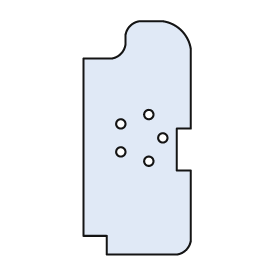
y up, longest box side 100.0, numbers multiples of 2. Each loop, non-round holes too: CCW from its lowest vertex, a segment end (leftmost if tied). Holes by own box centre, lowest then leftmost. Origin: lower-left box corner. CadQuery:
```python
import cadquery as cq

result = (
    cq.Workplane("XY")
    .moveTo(10.0, 0.0)
    .lineTo(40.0, 0.0)
    .threePointArc((44.0, 2.0), (46.0, 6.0))
    .lineTo(46.0, 36.0)
    .lineTo(40.0, 36.0)
    .lineTo(40.0, 54.0)
    .lineTo(46.0, 54.0)
    .lineTo(46.0, 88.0)
    .threePointArc((42.0, 96.0), (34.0, 100.0))
    .lineTo(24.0, 100.0)
    .threePointArc((20.0, 98.0), (18.0, 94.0))
    .lineTo(18.0, 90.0)
    .threePointArc((16.0, 86.0), (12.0, 84.0))
    .lineTo(0.0, 84.0)
    .lineTo(0.0, 8.0)
    .lineTo(10.0, 8.0)
    .close()
    .moveTo(28.0, 40.0)
    .circle(2.0)
    .moveTo(16.0, 44.0)
    .circle(2.0)
    .moveTo(34.0, 50.0)
    .circle(2.0)
    .moveTo(16.0, 56.0)
    .circle(2.0)
    .moveTo(28.0, 60.0)
    .circle(2.0)
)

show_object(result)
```